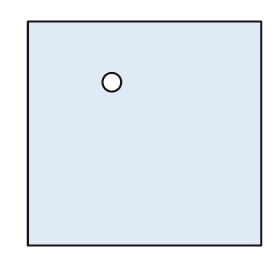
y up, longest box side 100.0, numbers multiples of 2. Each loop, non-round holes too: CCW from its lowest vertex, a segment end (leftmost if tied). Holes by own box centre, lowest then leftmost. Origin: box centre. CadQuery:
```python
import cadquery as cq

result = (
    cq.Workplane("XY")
    .moveTo(-50.0, -48.0)
    .lineTo(50.0, -48.0)
    .lineTo(50.0, 48.0)
    .lineTo(-50.0, 48.0)
    .close()
    .moveTo(-14.0, 22.0)
    .circle(4.0)
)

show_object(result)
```